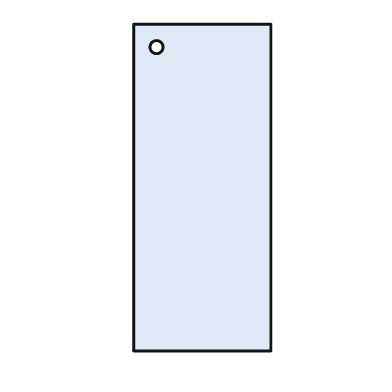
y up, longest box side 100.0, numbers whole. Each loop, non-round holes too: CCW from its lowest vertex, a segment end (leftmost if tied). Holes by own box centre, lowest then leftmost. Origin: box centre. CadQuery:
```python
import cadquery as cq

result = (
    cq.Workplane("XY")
    .moveTo(-21.0, -50.0)
    .lineTo(21.0, -50.0)
    .lineTo(21.0, 50.0)
    .lineTo(-21.0, 50.0)
    .close()
    .moveTo(-14.0, 43.0)
    .circle(2.0)
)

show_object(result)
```